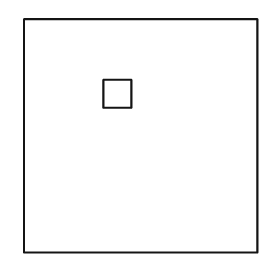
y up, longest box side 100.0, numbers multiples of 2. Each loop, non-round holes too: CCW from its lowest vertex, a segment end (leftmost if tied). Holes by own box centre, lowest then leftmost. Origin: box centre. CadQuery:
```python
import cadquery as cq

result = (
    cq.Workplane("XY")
    .moveTo(-50.0, -50.0)
    .lineTo(50.0, -50.0)
    .lineTo(50.0, 50.0)
    .lineTo(-50.0, 50.0)
    .close()
    .moveTo(-16.0, 12.0)
    .lineTo(-4.0, 12.0)
    .lineTo(-4.0, 24.0)
    .lineTo(-16.0, 24.0)
    .close()
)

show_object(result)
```